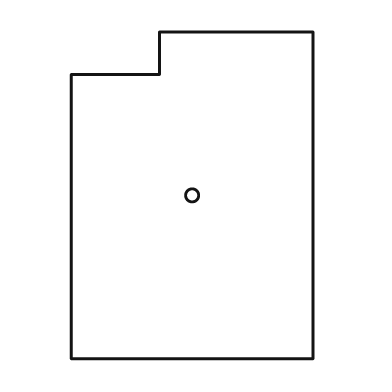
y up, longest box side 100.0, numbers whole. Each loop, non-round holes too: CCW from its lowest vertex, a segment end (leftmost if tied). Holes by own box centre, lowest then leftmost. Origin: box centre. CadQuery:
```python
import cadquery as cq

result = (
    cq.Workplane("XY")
    .moveTo(-37.0, -50.0)
    .lineTo(37.0, -50.0)
    .lineTo(37.0, 50.0)
    .lineTo(-10.0, 50.0)
    .lineTo(-10.0, 37.0)
    .lineTo(-37.0, 37.0)
    .close()
    .moveTo(0.0, 0.0)
    .circle(2.0)
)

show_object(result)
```